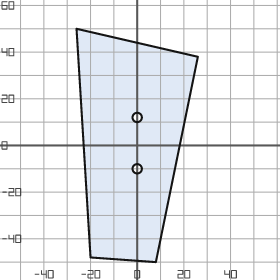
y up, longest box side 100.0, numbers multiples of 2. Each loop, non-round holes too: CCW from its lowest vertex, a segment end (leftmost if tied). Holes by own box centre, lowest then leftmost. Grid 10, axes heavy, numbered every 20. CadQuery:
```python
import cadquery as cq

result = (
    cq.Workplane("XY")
    .moveTo(8.0, -50.0)
    .lineTo(26.0, 38.0)
    .lineTo(-26.0, 50.0)
    .lineTo(-20.0, -48.0)
    .close()
    .moveTo(0.0, -10.0)
    .circle(2.0)
    .moveTo(0.0, 12.0)
    .circle(2.0)
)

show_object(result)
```